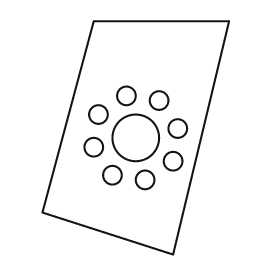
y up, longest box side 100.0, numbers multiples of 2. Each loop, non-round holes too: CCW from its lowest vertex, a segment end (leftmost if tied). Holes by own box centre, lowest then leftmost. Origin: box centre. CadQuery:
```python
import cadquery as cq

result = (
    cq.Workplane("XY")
    .moveTo(16.0, -50.0)
    .lineTo(40.0, 50.0)
    .lineTo(-18.0, 50.0)
    .lineTo(-40.0, -32.0)
    .close()
    .moveTo(4.0, -18.0)
    .circle(4.0)
    .moveTo(-10.0, -16.0)
    .circle(4.0)
    .moveTo(16.0, -10.0)
    .circle(4.0)
    .moveTo(-18.0, -4.0)
    .circle(4.0)
    .moveTo(0.0, 0.0)
    .circle(10.0)
    .moveTo(18.0, 4.0)
    .circle(4.0)
    .moveTo(-16.0, 10.0)
    .circle(4.0)
    .moveTo(10.0, 16.0)
    .circle(4.0)
    .moveTo(-4.0, 18.0)
    .circle(4.0)
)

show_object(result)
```